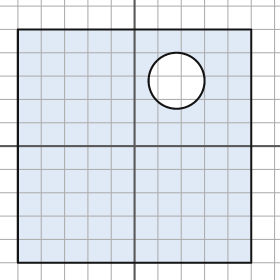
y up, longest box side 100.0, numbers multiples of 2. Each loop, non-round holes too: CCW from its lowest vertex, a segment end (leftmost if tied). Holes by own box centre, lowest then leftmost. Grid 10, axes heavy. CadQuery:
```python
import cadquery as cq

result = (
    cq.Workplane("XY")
    .moveTo(-50.0, -50.0)
    .lineTo(50.0, -50.0)
    .lineTo(50.0, 50.0)
    .lineTo(-50.0, 50.0)
    .close()
    .moveTo(18.0, 28.0)
    .circle(12.0)
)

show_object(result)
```